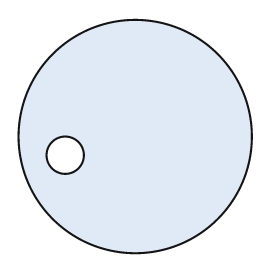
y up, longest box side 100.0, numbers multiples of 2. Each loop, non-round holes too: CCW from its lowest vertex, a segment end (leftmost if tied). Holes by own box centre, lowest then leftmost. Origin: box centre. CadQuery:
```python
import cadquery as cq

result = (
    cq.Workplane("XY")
    .moveTo(0.0, 0.0)
    .circle(50.0)
    .moveTo(-30.0, -8.0)
    .circle(8.0)
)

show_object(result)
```